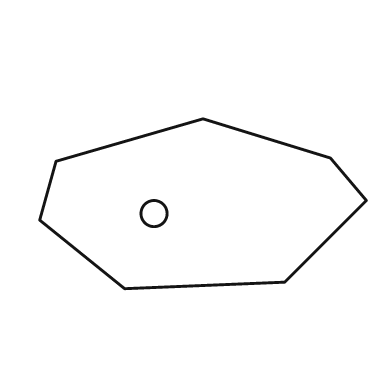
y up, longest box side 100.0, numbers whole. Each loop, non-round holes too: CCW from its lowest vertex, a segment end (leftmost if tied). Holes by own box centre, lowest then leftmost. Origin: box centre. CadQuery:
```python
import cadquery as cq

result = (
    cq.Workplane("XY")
    .moveTo(-24.0, -26.0)
    .lineTo(25.0, -24.0)
    .lineTo(50.0, 1.0)
    .lineTo(39.0, 14.0)
    .lineTo(0.0, 26.0)
    .lineTo(-45.0, 13.0)
    .lineTo(-50.0, -5.0)
    .close()
    .moveTo(-15.0, -3.0)
    .circle(4.0)
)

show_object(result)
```